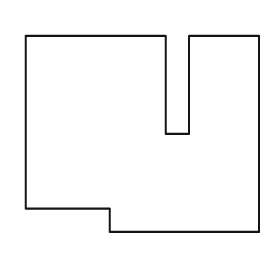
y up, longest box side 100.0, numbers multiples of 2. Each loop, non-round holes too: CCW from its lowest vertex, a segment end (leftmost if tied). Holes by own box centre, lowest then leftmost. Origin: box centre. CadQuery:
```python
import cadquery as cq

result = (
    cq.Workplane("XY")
    .moveTo(-14.0, -42.0)
    .lineTo(50.0, -42.0)
    .lineTo(50.0, 42.0)
    .lineTo(20.0, 42.0)
    .lineTo(20.0, 0.0)
    .lineTo(10.0, 0.0)
    .lineTo(10.0, 42.0)
    .lineTo(-50.0, 42.0)
    .lineTo(-50.0, -32.0)
    .lineTo(-14.0, -32.0)
    .close()
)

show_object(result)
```